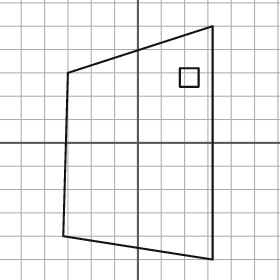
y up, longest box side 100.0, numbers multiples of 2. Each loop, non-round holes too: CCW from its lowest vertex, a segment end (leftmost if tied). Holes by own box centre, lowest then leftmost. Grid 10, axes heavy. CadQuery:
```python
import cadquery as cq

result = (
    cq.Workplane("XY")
    .moveTo(32.0, -50.0)
    .lineTo(32.0, 50.0)
    .lineTo(-30.0, 30.0)
    .lineTo(-32.0, -40.0)
    .close()
    .moveTo(18.0, 24.0)
    .lineTo(26.0, 24.0)
    .lineTo(26.0, 32.0)
    .lineTo(18.0, 32.0)
    .close()
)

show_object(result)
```